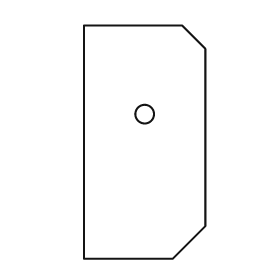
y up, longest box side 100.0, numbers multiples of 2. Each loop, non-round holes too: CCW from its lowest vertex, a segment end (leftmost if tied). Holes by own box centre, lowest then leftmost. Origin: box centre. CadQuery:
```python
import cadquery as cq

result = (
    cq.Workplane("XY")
    .moveTo(-26.0, -50.0)
    .lineTo(12.0, -50.0)
    .lineTo(26.0, -36.0)
    .lineTo(26.0, 40.0)
    .lineTo(16.0, 50.0)
    .lineTo(-26.0, 50.0)
    .close()
    .moveTo(0.0, 12.0)
    .circle(4.0)
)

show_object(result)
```